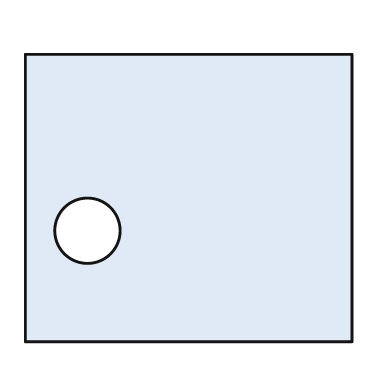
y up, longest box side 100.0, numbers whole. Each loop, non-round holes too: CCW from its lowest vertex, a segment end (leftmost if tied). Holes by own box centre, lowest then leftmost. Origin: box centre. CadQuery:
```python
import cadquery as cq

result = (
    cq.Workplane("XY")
    .moveTo(-50.0, -44.0)
    .lineTo(50.0, -44.0)
    .lineTo(50.0, 44.0)
    .lineTo(-50.0, 44.0)
    .close()
    .moveTo(-31.0, -10.0)
    .circle(10.0)
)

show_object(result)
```